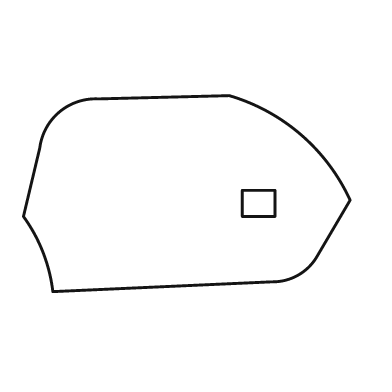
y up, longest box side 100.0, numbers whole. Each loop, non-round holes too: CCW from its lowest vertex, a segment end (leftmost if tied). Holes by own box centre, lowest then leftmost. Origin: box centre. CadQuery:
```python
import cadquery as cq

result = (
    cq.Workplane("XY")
    .moveTo(-41.0, -30.0)
    .lineTo(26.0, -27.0)
    .threePointArc((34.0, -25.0), (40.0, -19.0))
    .lineTo(50.0, -2.0)
    .threePointArc((35.0, 18.0), (13.0, 30.0))
    .lineTo(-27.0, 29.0)
    .threePointArc((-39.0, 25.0), (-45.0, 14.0))
    .lineTo(-50.0, -7.0)
    .threePointArc((-44.0, -18.0), (-41.0, -30.0))
    .close()
    .moveTo(17.0, -7.0)
    .lineTo(27.0, -7.0)
    .lineTo(27.0, 1.0)
    .lineTo(17.0, 1.0)
    .close()
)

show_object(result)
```